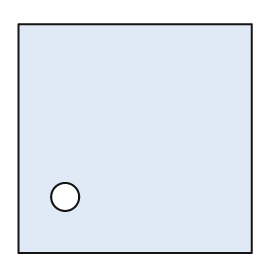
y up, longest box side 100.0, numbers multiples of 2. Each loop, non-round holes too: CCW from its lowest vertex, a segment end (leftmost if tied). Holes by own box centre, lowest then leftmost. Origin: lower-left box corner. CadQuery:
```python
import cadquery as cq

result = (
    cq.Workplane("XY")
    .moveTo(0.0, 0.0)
    .lineTo(100.0, 0.0)
    .lineTo(100.0, 98.0)
    .lineTo(0.0, 98.0)
    .close()
    .moveTo(20.0, 24.0)
    .circle(6.0)
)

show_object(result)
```